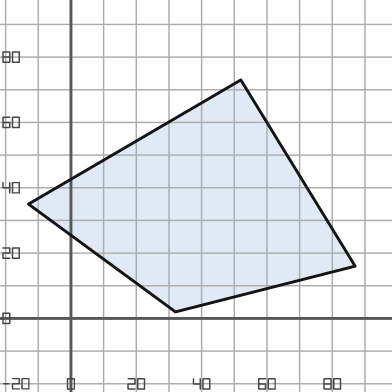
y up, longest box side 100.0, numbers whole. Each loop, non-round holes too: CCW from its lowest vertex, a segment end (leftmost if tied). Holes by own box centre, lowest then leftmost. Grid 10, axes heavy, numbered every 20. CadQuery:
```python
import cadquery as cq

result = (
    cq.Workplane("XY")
    .moveTo(32.0, 2.0)
    .lineTo(87.0, 16.0)
    .lineTo(52.0, 73.0)
    .lineTo(-13.0, 35.0)
    .close()
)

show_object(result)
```